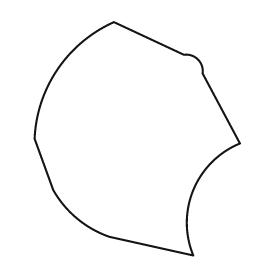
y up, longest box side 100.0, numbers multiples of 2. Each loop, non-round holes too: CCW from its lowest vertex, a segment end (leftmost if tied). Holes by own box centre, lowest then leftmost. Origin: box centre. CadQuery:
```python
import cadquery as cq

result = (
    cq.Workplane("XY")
    .moveTo(24.0, -50.0)
    .threePointArc((24.0, -22.0), (44.0, -2.0))
    .lineTo(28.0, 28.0)
    .threePointArc((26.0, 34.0), (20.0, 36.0))
    .lineTo(-10.0, 50.0)
    .threePointArc((-34.0, 30.0), (-44.0, 0.0))
    .lineTo(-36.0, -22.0)
    .threePointArc((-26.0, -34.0), (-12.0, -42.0))
    .close()
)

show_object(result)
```